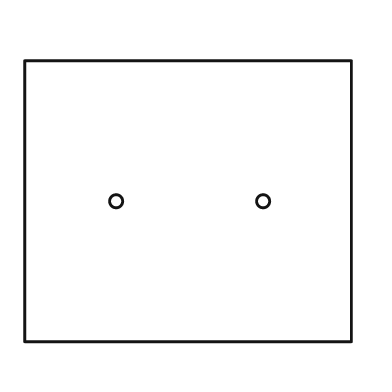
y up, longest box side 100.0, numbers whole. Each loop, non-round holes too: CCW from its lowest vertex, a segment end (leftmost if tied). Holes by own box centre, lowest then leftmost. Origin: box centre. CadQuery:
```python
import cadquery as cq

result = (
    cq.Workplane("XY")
    .moveTo(-50.0, -43.0)
    .lineTo(50.0, -43.0)
    .lineTo(50.0, 43.0)
    .lineTo(-50.0, 43.0)
    .close()
    .moveTo(-22.0, 0.0)
    .circle(2.0)
    .moveTo(23.0, 0.0)
    .circle(2.0)
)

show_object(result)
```